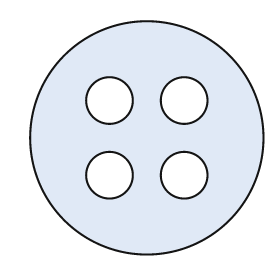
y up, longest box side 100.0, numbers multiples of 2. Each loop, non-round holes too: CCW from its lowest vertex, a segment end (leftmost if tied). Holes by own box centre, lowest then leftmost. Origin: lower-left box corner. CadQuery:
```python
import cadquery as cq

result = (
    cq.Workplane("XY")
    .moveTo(50.0, 50.0)
    .circle(50.0)
    .moveTo(34.0, 34.0)
    .circle(10.0)
    .moveTo(66.0, 34.0)
    .circle(10.0)
    .moveTo(34.0, 66.0)
    .circle(10.0)
    .moveTo(66.0, 66.0)
    .circle(10.0)
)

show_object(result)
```